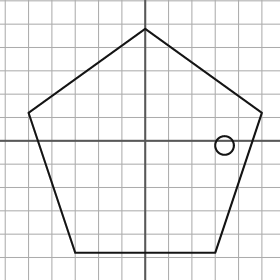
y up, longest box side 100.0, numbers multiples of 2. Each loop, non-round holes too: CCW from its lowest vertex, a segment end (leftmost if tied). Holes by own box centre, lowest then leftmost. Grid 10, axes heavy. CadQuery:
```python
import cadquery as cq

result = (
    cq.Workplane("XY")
    .moveTo(-30.0, -48.0)
    .lineTo(30.0, -48.0)
    .lineTo(50.0, 12.0)
    .lineTo(0.0, 48.0)
    .lineTo(-50.0, 12.0)
    .close()
    .moveTo(34.0, -2.0)
    .circle(4.0)
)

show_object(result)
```